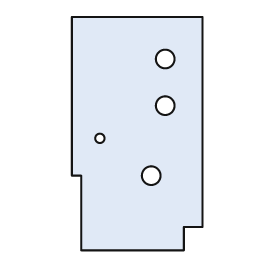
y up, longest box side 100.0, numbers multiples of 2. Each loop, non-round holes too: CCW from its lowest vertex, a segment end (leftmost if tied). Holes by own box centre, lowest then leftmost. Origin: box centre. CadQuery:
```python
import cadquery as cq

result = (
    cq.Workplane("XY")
    .moveTo(-24.0, -50.0)
    .lineTo(20.0, -50.0)
    .lineTo(20.0, -40.0)
    .lineTo(28.0, -40.0)
    .lineTo(28.0, 50.0)
    .lineTo(-28.0, 50.0)
    .lineTo(-28.0, -18.0)
    .lineTo(-24.0, -18.0)
    .close()
    .moveTo(6.0, -18.0)
    .circle(4.0)
    .moveTo(-16.0, -2.0)
    .circle(2.0)
    .moveTo(12.0, 12.0)
    .circle(4.0)
    .moveTo(12.0, 32.0)
    .circle(4.0)
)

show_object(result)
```